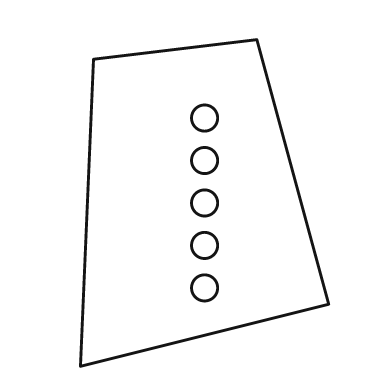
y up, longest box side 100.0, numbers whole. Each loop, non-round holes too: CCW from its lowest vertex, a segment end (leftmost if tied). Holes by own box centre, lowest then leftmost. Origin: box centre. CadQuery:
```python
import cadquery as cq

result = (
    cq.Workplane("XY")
    .moveTo(-38.0, -50.0)
    .lineTo(38.0, -31.0)
    .lineTo(16.0, 50.0)
    .lineTo(-34.0, 44.0)
    .close()
    .moveTo(0.0, -26.0)
    .circle(4.0)
    .moveTo(0.0, -13.0)
    .circle(4.0)
    .moveTo(0.0, 0.0)
    .circle(4.0)
    .moveTo(0.0, 13.0)
    .circle(4.0)
    .moveTo(0.0, 26.0)
    .circle(4.0)
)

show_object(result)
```